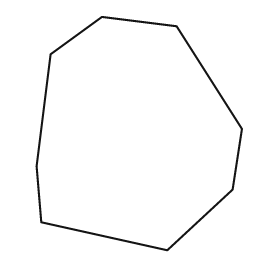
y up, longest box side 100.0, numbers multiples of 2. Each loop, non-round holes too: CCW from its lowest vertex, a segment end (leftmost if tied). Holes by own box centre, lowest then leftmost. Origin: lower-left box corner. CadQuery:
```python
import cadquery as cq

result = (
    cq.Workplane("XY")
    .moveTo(56.0, 0.0)
    .lineTo(84.0, 26.0)
    .lineTo(88.0, 52.0)
    .lineTo(60.0, 96.0)
    .lineTo(28.0, 100.0)
    .lineTo(6.0, 84.0)
    .lineTo(0.0, 36.0)
    .lineTo(2.0, 12.0)
    .close()
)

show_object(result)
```